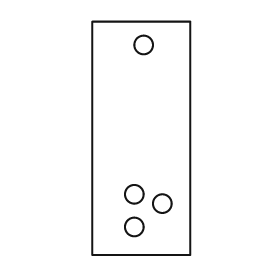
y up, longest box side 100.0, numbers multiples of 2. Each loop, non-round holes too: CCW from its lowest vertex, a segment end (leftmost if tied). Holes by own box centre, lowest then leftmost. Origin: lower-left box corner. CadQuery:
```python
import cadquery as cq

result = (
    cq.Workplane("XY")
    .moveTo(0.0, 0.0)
    .lineTo(42.0, 0.0)
    .lineTo(42.0, 100.0)
    .lineTo(0.0, 100.0)
    .close()
    .moveTo(18.0, 12.0)
    .circle(4.0)
    .moveTo(30.0, 22.0)
    .circle(4.0)
    .moveTo(18.0, 26.0)
    .circle(4.0)
    .moveTo(22.0, 90.0)
    .circle(4.0)
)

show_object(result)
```